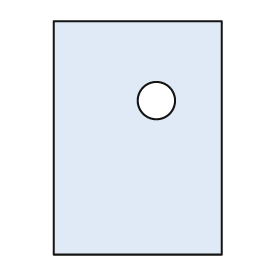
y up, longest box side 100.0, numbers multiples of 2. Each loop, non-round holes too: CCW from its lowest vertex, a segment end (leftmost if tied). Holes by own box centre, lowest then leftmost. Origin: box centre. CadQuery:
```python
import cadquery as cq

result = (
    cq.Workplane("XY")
    .moveTo(-36.0, -50.0)
    .lineTo(36.0, -50.0)
    .lineTo(36.0, 50.0)
    .lineTo(-36.0, 50.0)
    .close()
    .moveTo(8.0, 16.0)
    .circle(8.0)
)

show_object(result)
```